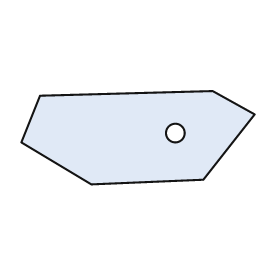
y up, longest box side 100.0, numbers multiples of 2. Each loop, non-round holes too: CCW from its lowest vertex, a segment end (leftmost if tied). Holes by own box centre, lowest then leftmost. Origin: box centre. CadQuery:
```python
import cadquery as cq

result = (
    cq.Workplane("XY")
    .moveTo(-20.0, -20.0)
    .lineTo(28.0, -18.0)
    .lineTo(50.0, 10.0)
    .lineTo(32.0, 20.0)
    .lineTo(-42.0, 18.0)
    .lineTo(-50.0, -2.0)
    .close()
    .moveTo(16.0, 2.0)
    .circle(4.0)
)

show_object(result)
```